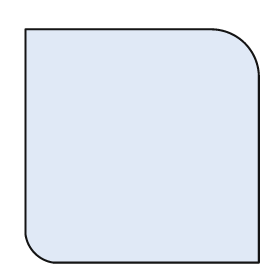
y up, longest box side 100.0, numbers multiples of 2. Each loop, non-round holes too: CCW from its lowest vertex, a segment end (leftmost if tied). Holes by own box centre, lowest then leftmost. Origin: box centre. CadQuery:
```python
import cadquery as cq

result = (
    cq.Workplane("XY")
    .moveTo(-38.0, -50.0)
    .lineTo(50.0, -50.0)
    .lineTo(50.0, 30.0)
    .threePointArc((44.0, 44.0), (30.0, 50.0))
    .lineTo(-50.0, 50.0)
    .lineTo(-50.0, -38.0)
    .threePointArc((-46.0, -46.0), (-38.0, -50.0))
    .close()
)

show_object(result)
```